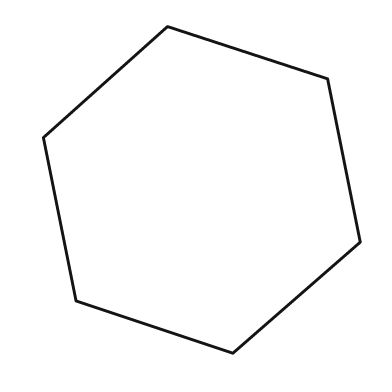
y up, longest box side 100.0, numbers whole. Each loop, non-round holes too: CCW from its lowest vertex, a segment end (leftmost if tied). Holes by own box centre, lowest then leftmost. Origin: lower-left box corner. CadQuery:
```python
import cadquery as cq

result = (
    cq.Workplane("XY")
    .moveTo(58.0, 0.0)
    .lineTo(97.0, 34.0)
    .lineTo(87.0, 84.0)
    .lineTo(38.0, 100.0)
    .lineTo(0.0, 66.0)
    .lineTo(10.0, 16.0)
    .close()
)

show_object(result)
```